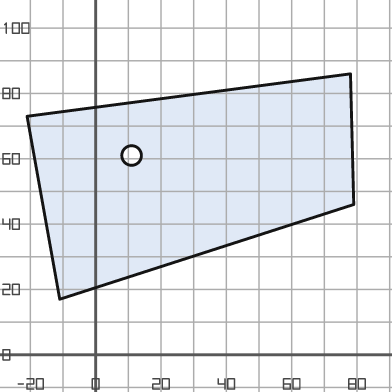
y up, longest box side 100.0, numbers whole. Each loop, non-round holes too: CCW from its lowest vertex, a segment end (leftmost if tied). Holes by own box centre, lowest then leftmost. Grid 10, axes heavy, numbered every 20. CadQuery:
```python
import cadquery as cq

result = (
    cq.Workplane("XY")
    .moveTo(-11.0, 17.0)
    .lineTo(79.0, 46.0)
    .lineTo(78.0, 86.0)
    .lineTo(-21.0, 73.0)
    .close()
    .moveTo(11.0, 61.0)
    .circle(3.0)
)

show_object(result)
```